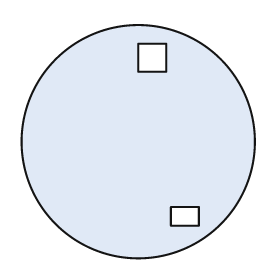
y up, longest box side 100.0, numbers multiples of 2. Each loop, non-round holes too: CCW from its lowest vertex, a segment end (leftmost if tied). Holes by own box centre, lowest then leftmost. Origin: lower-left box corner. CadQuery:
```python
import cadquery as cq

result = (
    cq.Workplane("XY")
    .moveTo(50.0, 50.0)
    .circle(50.0)
    .moveTo(64.0, 14.0)
    .lineTo(76.0, 14.0)
    .lineTo(76.0, 22.0)
    .lineTo(64.0, 22.0)
    .close()
    .moveTo(50.0, 80.0)
    .lineTo(62.0, 80.0)
    .lineTo(62.0, 92.0)
    .lineTo(50.0, 92.0)
    .close()
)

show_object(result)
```